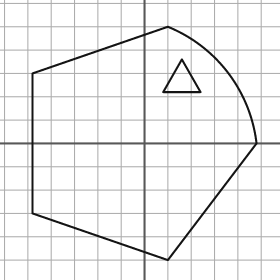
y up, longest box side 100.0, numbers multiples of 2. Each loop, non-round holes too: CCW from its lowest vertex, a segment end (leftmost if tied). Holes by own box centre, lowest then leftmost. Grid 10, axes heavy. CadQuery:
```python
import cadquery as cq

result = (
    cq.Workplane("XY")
    .moveTo(10.0, -50.0)
    .lineTo(48.0, 0.0)
    .threePointArc((36.0, 30.0), (10.0, 50.0))
    .lineTo(-48.0, 30.0)
    .lineTo(-48.0, -30.0)
    .close()
    .moveTo(8.0, 22.0)
    .lineTo(24.0, 22.0)
    .lineTo(16.0, 36.0)
    .close()
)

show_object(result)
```